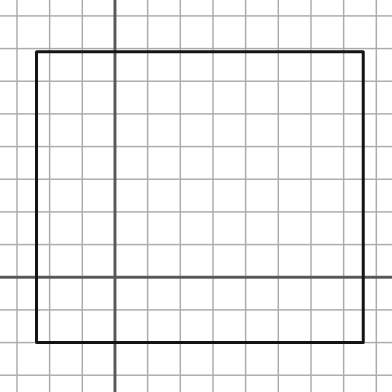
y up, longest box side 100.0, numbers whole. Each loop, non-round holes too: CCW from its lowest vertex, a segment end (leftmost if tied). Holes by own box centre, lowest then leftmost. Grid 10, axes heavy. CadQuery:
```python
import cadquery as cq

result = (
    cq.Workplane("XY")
    .moveTo(-24.0, -20.0)
    .lineTo(76.0, -20.0)
    .lineTo(76.0, 69.0)
    .lineTo(-24.0, 69.0)
    .close()
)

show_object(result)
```